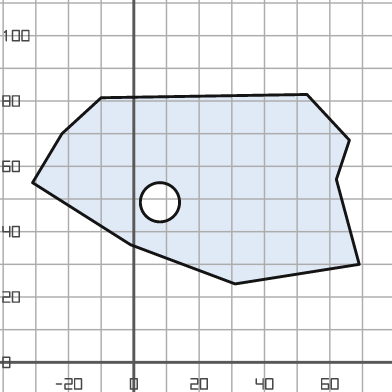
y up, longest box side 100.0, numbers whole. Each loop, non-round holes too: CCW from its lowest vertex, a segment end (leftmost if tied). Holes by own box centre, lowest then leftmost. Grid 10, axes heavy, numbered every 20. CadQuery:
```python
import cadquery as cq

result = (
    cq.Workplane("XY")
    .moveTo(31.0, 24.0)
    .lineTo(69.0, 30.0)
    .lineTo(62.0, 56.0)
    .lineTo(66.0, 68.0)
    .lineTo(53.0, 82.0)
    .lineTo(-10.0, 81.0)
    .lineTo(-22.0, 70.0)
    .lineTo(-31.0, 55.0)
    .lineTo(-1.0, 36.0)
    .close()
    .moveTo(8.0, 49.0)
    .circle(6.0)
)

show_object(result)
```